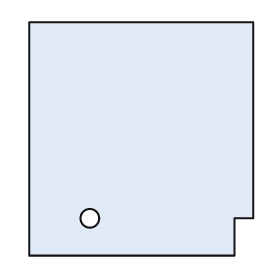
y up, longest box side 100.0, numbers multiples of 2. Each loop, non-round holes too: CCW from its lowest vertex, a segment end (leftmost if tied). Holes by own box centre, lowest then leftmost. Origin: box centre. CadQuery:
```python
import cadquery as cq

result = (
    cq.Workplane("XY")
    .moveTo(-48.0, -50.0)
    .lineTo(40.0, -50.0)
    .lineTo(40.0, -34.0)
    .lineTo(48.0, -34.0)
    .lineTo(48.0, 50.0)
    .lineTo(-48.0, 50.0)
    .close()
    .moveTo(-22.0, -34.0)
    .circle(4.0)
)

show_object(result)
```